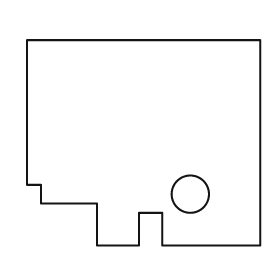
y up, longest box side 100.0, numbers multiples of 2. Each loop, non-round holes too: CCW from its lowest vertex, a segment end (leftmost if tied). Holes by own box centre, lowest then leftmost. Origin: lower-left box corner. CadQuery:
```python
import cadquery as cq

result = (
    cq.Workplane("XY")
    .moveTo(30.0, 0.0)
    .lineTo(48.0, 0.0)
    .lineTo(48.0, 14.0)
    .lineTo(58.0, 14.0)
    .lineTo(58.0, 0.0)
    .lineTo(100.0, 0.0)
    .lineTo(100.0, 88.0)
    .lineTo(0.0, 88.0)
    .lineTo(0.0, 26.0)
    .lineTo(6.0, 26.0)
    .lineTo(6.0, 18.0)
    .lineTo(30.0, 18.0)
    .close()
    .moveTo(70.0, 22.0)
    .circle(8.0)
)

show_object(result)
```